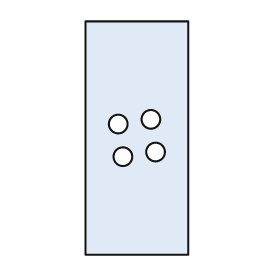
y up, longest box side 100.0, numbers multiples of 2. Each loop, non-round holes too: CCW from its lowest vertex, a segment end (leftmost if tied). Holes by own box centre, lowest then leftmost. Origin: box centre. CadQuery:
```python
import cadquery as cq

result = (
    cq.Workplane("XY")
    .moveTo(-22.0, -50.0)
    .lineTo(22.0, -50.0)
    .lineTo(22.0, 50.0)
    .lineTo(-22.0, 50.0)
    .close()
    .moveTo(-6.0, -8.0)
    .circle(4.0)
    .moveTo(8.0, -6.0)
    .circle(4.0)
    .moveTo(-8.0, 6.0)
    .circle(4.0)
    .moveTo(6.0, 8.0)
    .circle(4.0)
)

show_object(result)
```